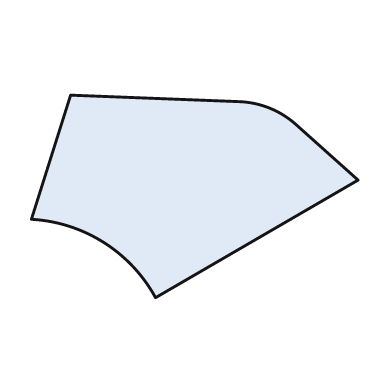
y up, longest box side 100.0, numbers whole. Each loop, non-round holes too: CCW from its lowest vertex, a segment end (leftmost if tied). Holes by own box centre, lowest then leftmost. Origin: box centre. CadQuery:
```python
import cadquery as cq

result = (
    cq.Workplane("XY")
    .moveTo(-12.0, -31.0)
    .lineTo(50.0, 5.0)
    .lineTo(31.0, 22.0)
    .threePointArc((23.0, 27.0), (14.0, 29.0))
    .lineTo(-38.0, 31.0)
    .lineTo(-50.0, -7.0)
    .threePointArc((-28.0, -14.0), (-12.0, -31.0))
    .close()
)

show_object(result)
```